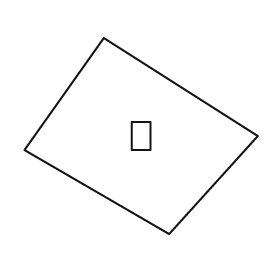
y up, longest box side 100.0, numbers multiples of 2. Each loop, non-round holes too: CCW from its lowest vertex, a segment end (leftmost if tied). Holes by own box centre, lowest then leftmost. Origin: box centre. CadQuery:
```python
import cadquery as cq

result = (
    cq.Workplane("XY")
    .moveTo(12.0, -42.0)
    .lineTo(50.0, 0.0)
    .lineTo(-16.0, 42.0)
    .lineTo(-50.0, -6.0)
    .close()
    .moveTo(-4.0, -6.0)
    .lineTo(4.0, -6.0)
    .lineTo(4.0, 6.0)
    .lineTo(-4.0, 6.0)
    .close()
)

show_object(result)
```